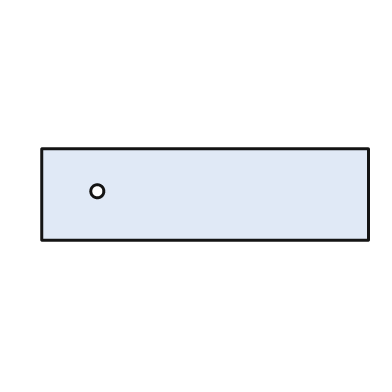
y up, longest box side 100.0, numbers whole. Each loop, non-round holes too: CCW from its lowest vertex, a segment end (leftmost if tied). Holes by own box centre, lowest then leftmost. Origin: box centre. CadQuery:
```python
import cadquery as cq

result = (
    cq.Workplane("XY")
    .moveTo(-50.0, -14.0)
    .lineTo(50.0, -14.0)
    .lineTo(50.0, 14.0)
    .lineTo(-50.0, 14.0)
    .close()
    .moveTo(-33.0, 1.0)
    .circle(2.0)
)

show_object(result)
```